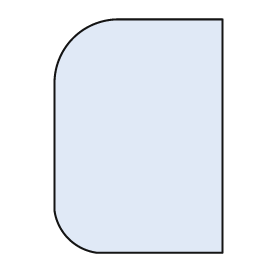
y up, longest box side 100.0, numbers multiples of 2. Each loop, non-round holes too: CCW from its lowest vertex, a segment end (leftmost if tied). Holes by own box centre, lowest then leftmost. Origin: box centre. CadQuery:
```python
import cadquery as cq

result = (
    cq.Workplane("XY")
    .moveTo(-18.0, -50.0)
    .lineTo(36.0, -50.0)
    .lineTo(36.0, 50.0)
    .lineTo(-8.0, 50.0)
    .threePointArc((-28.0, 42.0), (-36.0, 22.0))
    .lineTo(-36.0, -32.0)
    .threePointArc((-30.0, -44.0), (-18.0, -50.0))
    .close()
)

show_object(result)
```